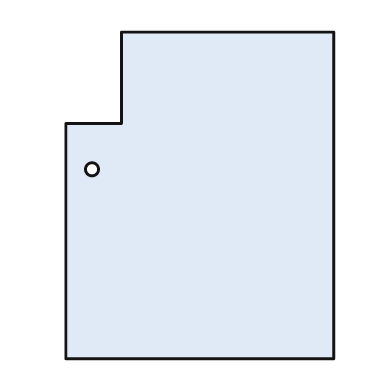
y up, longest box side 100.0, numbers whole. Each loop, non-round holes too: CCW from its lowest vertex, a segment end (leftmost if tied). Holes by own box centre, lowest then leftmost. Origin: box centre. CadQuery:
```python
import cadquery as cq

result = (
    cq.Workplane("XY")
    .moveTo(-41.0, -50.0)
    .lineTo(41.0, -50.0)
    .lineTo(41.0, 50.0)
    .lineTo(-24.0, 50.0)
    .lineTo(-24.0, 22.0)
    .lineTo(-41.0, 22.0)
    .close()
    .moveTo(-33.0, 8.0)
    .circle(2.0)
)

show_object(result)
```